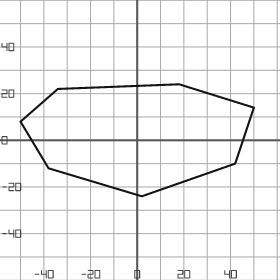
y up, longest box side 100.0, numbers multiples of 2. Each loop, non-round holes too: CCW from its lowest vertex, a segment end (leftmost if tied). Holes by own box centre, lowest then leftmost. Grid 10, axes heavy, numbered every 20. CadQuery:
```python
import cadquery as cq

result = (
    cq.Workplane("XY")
    .moveTo(2.0, -24.0)
    .lineTo(42.0, -10.0)
    .lineTo(50.0, 14.0)
    .lineTo(18.0, 24.0)
    .lineTo(-34.0, 22.0)
    .lineTo(-50.0, 8.0)
    .lineTo(-38.0, -12.0)
    .close()
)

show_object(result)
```